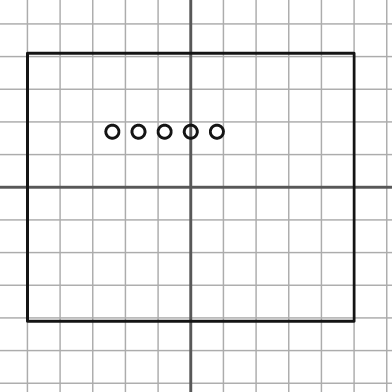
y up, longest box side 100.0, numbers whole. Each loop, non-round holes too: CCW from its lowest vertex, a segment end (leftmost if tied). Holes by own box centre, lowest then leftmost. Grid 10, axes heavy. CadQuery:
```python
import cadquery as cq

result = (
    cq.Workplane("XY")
    .moveTo(-50.0, -41.0)
    .lineTo(50.0, -41.0)
    .lineTo(50.0, 41.0)
    .lineTo(-50.0, 41.0)
    .close()
    .moveTo(-24.0, 17.0)
    .circle(2.0)
    .moveTo(-16.0, 17.0)
    .circle(2.0)
    .moveTo(-8.0, 17.0)
    .circle(2.0)
    .moveTo(0.0, 17.0)
    .circle(2.0)
    .moveTo(8.0, 17.0)
    .circle(2.0)
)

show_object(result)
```